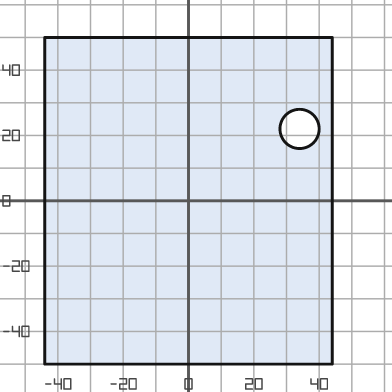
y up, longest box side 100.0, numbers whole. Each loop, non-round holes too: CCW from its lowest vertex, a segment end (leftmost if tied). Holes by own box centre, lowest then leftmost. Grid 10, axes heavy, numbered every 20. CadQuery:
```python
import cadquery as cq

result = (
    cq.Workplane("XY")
    .moveTo(-44.0, -50.0)
    .lineTo(44.0, -50.0)
    .lineTo(44.0, 50.0)
    .lineTo(-44.0, 50.0)
    .close()
    .moveTo(34.0, 22.0)
    .circle(6.0)
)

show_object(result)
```